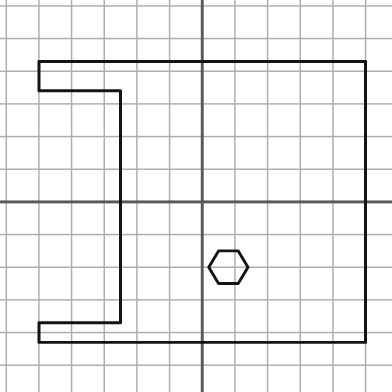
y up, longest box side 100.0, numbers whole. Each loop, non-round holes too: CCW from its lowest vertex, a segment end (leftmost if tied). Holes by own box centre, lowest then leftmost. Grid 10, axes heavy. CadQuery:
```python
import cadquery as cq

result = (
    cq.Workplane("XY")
    .moveTo(-50.0, -43.0)
    .lineTo(50.0, -43.0)
    .lineTo(50.0, 43.0)
    .lineTo(-50.0, 43.0)
    .lineTo(-50.0, 34.0)
    .lineTo(-25.0, 34.0)
    .lineTo(-25.0, -37.0)
    .lineTo(-50.0, -37.0)
    .close()
    .moveTo(5.0, -25.0)
    .lineTo(11.0, -25.0)
    .lineTo(14.0, -20.0)
    .lineTo(11.0, -15.0)
    .lineTo(5.0, -15.0)
    .lineTo(2.0, -20.0)
    .close()
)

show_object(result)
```